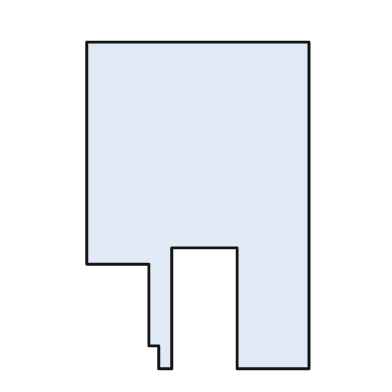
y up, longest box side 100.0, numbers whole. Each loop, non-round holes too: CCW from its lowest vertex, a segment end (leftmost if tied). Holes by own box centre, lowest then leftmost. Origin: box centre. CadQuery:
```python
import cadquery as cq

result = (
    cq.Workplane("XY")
    .moveTo(-12.0, -50.0)
    .lineTo(-8.0, -50.0)
    .lineTo(-8.0, -13.0)
    .lineTo(12.0, -13.0)
    .lineTo(12.0, -50.0)
    .lineTo(34.0, -50.0)
    .lineTo(34.0, 50.0)
    .lineTo(-34.0, 50.0)
    .lineTo(-34.0, -18.0)
    .lineTo(-15.0, -18.0)
    .lineTo(-15.0, -43.0)
    .lineTo(-12.0, -43.0)
    .close()
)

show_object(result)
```